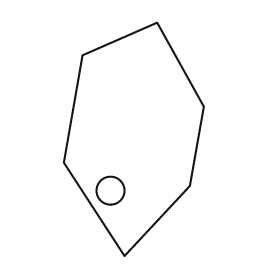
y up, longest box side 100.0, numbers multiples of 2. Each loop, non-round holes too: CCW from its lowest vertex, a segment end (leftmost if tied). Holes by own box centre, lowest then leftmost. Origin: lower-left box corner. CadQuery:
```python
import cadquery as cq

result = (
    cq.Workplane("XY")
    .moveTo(26.0, 0.0)
    .lineTo(54.0, 30.0)
    .lineTo(60.0, 64.0)
    .lineTo(40.0, 100.0)
    .lineTo(8.0, 86.0)
    .lineTo(0.0, 40.0)
    .close()
    .moveTo(20.0, 28.0)
    .circle(6.0)
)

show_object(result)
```